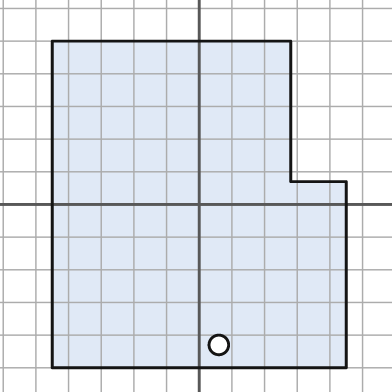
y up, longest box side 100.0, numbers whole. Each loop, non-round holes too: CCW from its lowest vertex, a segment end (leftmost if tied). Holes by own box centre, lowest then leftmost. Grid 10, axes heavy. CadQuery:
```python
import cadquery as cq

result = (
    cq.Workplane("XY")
    .moveTo(-45.0, -50.0)
    .lineTo(45.0, -50.0)
    .lineTo(45.0, 7.0)
    .lineTo(28.0, 7.0)
    .lineTo(28.0, 50.0)
    .lineTo(-45.0, 50.0)
    .close()
    .moveTo(6.0, -43.0)
    .circle(3.0)
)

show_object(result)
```